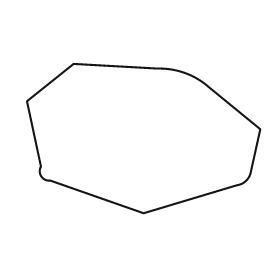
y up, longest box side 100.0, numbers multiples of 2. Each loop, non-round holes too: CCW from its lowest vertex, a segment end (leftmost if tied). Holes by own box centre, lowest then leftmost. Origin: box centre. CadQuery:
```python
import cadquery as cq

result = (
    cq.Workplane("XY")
    .moveTo(0.0, -32.0)
    .lineTo(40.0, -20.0)
    .threePointArc((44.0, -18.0), (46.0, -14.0))
    .lineTo(50.0, 4.0)
    .lineTo(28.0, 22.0)
    .threePointArc((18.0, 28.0), (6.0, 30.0))
    .lineTo(-30.0, 32.0)
    .lineTo(-50.0, 16.0)
    .lineTo(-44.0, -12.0)
    .threePointArc((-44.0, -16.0), (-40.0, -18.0))
    .close()
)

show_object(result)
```